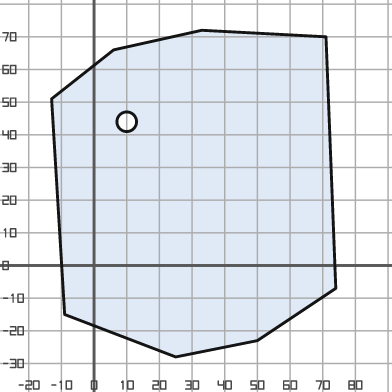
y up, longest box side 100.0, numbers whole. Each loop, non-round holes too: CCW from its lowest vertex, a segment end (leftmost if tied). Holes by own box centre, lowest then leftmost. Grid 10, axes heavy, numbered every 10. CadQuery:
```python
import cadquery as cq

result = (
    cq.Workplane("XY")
    .moveTo(25.0, -28.0)
    .lineTo(50.0, -23.0)
    .lineTo(74.0, -7.0)
    .lineTo(71.0, 70.0)
    .lineTo(33.0, 72.0)
    .lineTo(6.0, 66.0)
    .lineTo(-13.0, 51.0)
    .lineTo(-9.0, -15.0)
    .close()
    .moveTo(10.0, 44.0)
    .circle(3.0)
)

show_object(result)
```